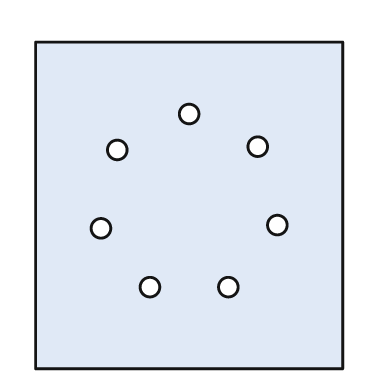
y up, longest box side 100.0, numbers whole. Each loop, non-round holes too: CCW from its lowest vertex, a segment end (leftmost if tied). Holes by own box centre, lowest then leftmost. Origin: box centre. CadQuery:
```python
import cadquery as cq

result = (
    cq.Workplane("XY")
    .moveTo(-47.0, -50.0)
    .lineTo(47.0, -50.0)
    .lineTo(47.0, 50.0)
    .lineTo(-47.0, 50.0)
    .close()
    .moveTo(-12.0, -25.0)
    .circle(3.0)
    .moveTo(12.0, -25.0)
    .circle(3.0)
    .moveTo(-27.0, -7.0)
    .circle(3.0)
    .moveTo(27.0, -6.0)
    .circle(3.0)
    .moveTo(-22.0, 17.0)
    .circle(3.0)
    .moveTo(21.0, 18.0)
    .circle(3.0)
    .moveTo(0.0, 28.0)
    .circle(3.0)
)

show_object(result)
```